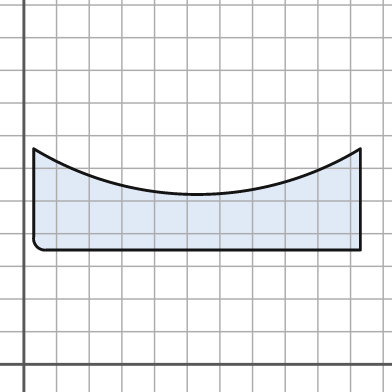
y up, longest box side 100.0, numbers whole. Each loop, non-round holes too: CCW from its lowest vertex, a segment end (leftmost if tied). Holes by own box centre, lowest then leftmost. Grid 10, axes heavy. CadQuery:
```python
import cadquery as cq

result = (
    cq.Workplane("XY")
    .moveTo(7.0, 35.0)
    .lineTo(103.0, 35.0)
    .lineTo(103.0, 66.0)
    .threePointArc((53.0, 52.0), (3.0, 66.0))
    .lineTo(3.0, 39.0)
    .threePointArc((4.0, 36.0), (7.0, 35.0))
    .close()
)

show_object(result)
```